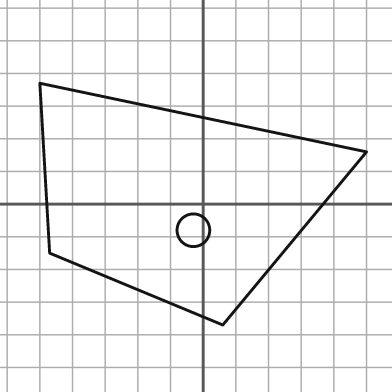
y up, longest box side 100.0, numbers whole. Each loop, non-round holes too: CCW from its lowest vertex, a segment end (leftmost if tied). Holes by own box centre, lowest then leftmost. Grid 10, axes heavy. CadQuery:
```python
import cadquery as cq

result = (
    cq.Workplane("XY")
    .moveTo(6.0, -37.0)
    .lineTo(50.0, 16.0)
    .lineTo(-50.0, 37.0)
    .lineTo(-47.0, -15.0)
    .close()
    .moveTo(-3.0, -8.0)
    .circle(5.0)
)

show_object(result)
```